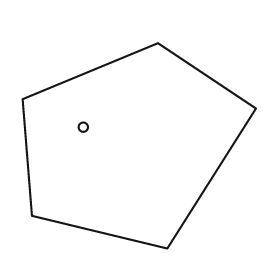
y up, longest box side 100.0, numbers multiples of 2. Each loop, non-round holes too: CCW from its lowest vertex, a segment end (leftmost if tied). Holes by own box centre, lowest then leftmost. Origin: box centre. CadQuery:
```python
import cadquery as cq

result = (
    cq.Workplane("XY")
    .moveTo(12.0, -44.0)
    .lineTo(50.0, 16.0)
    .lineTo(8.0, 44.0)
    .lineTo(-50.0, 20.0)
    .lineTo(-46.0, -30.0)
    .close()
    .moveTo(-24.0, 8.0)
    .circle(2.0)
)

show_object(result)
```